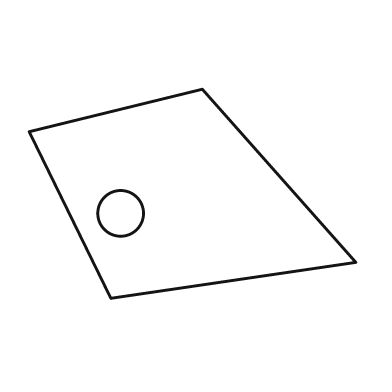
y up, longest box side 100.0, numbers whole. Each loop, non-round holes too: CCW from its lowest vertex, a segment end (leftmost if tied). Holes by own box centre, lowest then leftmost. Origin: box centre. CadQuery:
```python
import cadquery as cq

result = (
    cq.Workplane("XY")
    .moveTo(-25.0, -32.0)
    .lineTo(50.0, -21.0)
    .lineTo(3.0, 32.0)
    .lineTo(-50.0, 19.0)
    .close()
    .moveTo(-22.0, -6.0)
    .circle(7.0)
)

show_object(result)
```